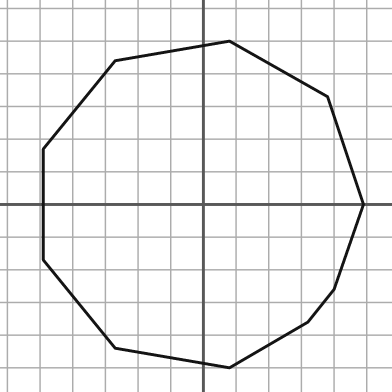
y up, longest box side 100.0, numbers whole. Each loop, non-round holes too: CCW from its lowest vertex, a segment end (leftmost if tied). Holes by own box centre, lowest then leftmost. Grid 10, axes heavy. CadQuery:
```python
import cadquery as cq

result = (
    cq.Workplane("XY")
    .moveTo(8.0, -50.0)
    .lineTo(32.0, -36.0)
    .lineTo(40.0, -26.0)
    .lineTo(49.0, 0.0)
    .lineTo(38.0, 33.0)
    .lineTo(8.0, 50.0)
    .lineTo(-27.0, 44.0)
    .lineTo(-49.0, 17.0)
    .lineTo(-49.0, -17.0)
    .lineTo(-27.0, -44.0)
    .close()
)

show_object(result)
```